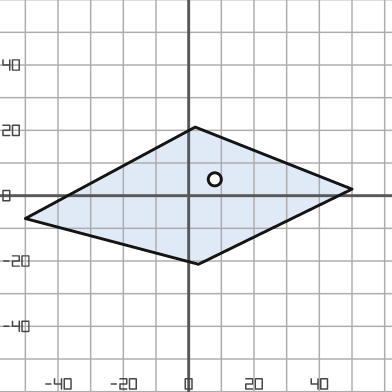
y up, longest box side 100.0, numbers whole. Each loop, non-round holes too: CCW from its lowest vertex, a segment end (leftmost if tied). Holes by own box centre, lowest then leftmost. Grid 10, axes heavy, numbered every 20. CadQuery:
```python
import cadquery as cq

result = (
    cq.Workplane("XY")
    .moveTo(3.0, -21.0)
    .lineTo(50.0, 2.0)
    .lineTo(2.0, 21.0)
    .lineTo(-50.0, -7.0)
    .close()
    .moveTo(8.0, 5.0)
    .circle(2.0)
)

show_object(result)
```